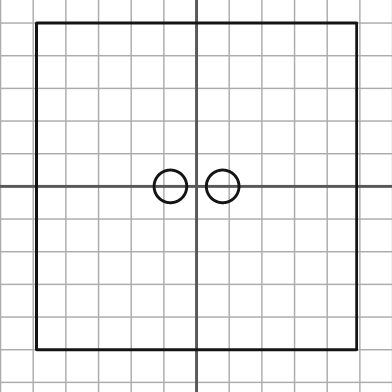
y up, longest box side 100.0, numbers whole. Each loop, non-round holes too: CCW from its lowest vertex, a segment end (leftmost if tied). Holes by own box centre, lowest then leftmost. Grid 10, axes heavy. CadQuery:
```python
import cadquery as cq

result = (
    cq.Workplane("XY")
    .moveTo(-49.0, -50.0)
    .lineTo(49.0, -50.0)
    .lineTo(49.0, 50.0)
    .lineTo(-49.0, 50.0)
    .close()
    .moveTo(-8.0, 0.0)
    .circle(5.0)
    .moveTo(8.0, 0.0)
    .circle(5.0)
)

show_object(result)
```